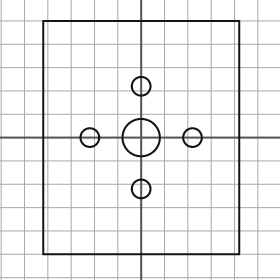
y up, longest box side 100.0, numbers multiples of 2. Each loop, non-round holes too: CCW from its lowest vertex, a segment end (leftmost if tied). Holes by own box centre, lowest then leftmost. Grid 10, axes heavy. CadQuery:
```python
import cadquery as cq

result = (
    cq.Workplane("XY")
    .moveTo(-42.0, -50.0)
    .lineTo(42.0, -50.0)
    .lineTo(42.0, 50.0)
    .lineTo(-42.0, 50.0)
    .close()
    .moveTo(0.0, -22.0)
    .circle(4.0)
    .moveTo(-22.0, 0.0)
    .circle(4.0)
    .moveTo(0.0, 0.0)
    .circle(8.0)
    .moveTo(22.0, 0.0)
    .circle(4.0)
    .moveTo(0.0, 22.0)
    .circle(4.0)
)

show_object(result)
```